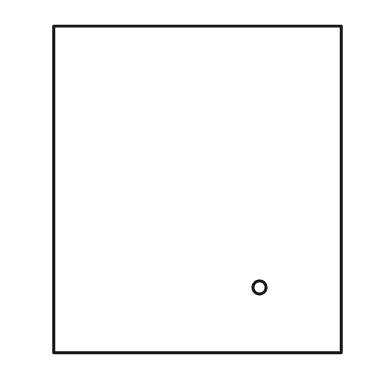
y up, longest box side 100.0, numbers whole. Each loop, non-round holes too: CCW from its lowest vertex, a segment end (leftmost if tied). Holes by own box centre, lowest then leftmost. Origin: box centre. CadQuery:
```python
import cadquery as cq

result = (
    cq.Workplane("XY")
    .moveTo(-44.0, -50.0)
    .lineTo(44.0, -50.0)
    .lineTo(44.0, 50.0)
    .lineTo(-44.0, 50.0)
    .close()
    .moveTo(19.0, -30.0)
    .circle(2.0)
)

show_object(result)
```